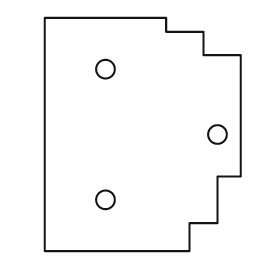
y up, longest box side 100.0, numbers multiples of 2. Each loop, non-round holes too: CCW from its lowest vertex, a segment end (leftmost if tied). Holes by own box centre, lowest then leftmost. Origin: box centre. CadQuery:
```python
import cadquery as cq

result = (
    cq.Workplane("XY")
    .moveTo(-42.0, -50.0)
    .lineTo(20.0, -50.0)
    .lineTo(20.0, -38.0)
    .lineTo(32.0, -38.0)
    .lineTo(32.0, -18.0)
    .lineTo(42.0, -18.0)
    .lineTo(42.0, 34.0)
    .lineTo(26.0, 34.0)
    .lineTo(26.0, 44.0)
    .lineTo(10.0, 44.0)
    .lineTo(10.0, 50.0)
    .lineTo(-42.0, 50.0)
    .close()
    .moveTo(-16.0, -28.0)
    .circle(4.0)
    .moveTo(32.0, 0.0)
    .circle(4.0)
    .moveTo(-16.0, 28.0)
    .circle(4.0)
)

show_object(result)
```